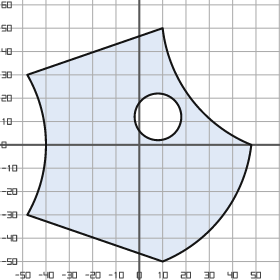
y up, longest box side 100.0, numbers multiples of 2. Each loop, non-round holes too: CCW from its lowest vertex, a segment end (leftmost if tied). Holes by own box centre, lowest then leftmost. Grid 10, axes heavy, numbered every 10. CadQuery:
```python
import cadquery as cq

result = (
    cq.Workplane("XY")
    .moveTo(10.0, -50.0)
    .threePointArc((36.0, -30.0), (48.0, 0.0))
    .threePointArc((22.0, 20.0), (10.0, 50.0))
    .lineTo(-48.0, 30.0)
    .threePointArc((-40.0, 0.0), (-48.0, -30.0))
    .close()
    .moveTo(8.0, 12.0)
    .circle(10.0)
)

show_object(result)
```